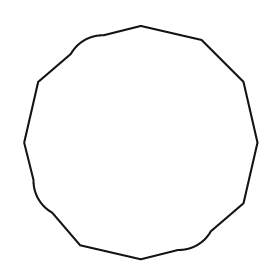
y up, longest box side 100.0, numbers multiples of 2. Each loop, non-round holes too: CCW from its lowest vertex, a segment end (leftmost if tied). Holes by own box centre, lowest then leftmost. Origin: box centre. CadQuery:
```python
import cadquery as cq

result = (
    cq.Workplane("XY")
    .moveTo(0.0, -50.0)
    .lineTo(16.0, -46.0)
    .threePointArc((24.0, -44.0), (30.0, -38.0))
    .lineTo(44.0, -26.0)
    .lineTo(50.0, 0.0)
    .lineTo(44.0, 26.0)
    .lineTo(26.0, 44.0)
    .lineTo(0.0, 50.0)
    .lineTo(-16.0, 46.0)
    .threePointArc((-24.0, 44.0), (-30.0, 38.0))
    .lineTo(-44.0, 26.0)
    .lineTo(-50.0, 0.0)
    .lineTo(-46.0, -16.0)
    .threePointArc((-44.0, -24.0), (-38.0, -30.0))
    .lineTo(-26.0, -44.0)
    .close()
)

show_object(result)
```